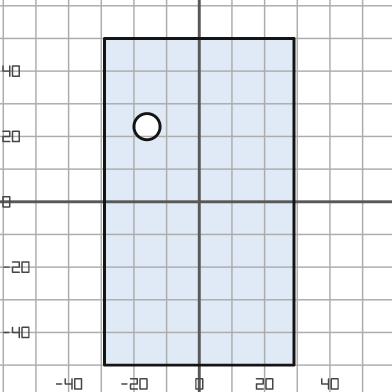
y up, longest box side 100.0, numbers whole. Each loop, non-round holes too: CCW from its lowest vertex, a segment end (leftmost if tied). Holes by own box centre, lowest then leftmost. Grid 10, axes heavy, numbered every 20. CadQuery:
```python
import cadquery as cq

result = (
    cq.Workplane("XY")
    .moveTo(-29.0, -50.0)
    .lineTo(29.0, -50.0)
    .lineTo(29.0, 50.0)
    .lineTo(-29.0, 50.0)
    .close()
    .moveTo(-16.0, 23.0)
    .circle(4.0)
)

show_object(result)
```